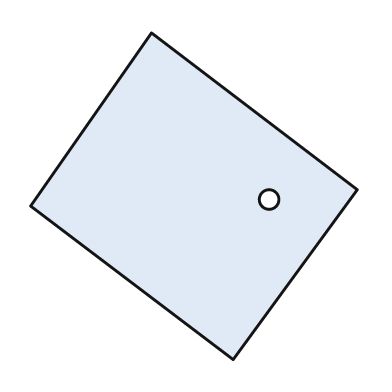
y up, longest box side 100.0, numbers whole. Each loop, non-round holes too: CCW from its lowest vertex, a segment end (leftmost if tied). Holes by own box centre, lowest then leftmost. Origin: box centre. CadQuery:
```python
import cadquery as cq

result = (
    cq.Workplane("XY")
    .moveTo(12.0, -50.0)
    .lineTo(50.0, 2.0)
    .lineTo(-13.0, 50.0)
    .lineTo(-50.0, -3.0)
    .close()
    .moveTo(23.0, -1.0)
    .circle(3.0)
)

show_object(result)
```